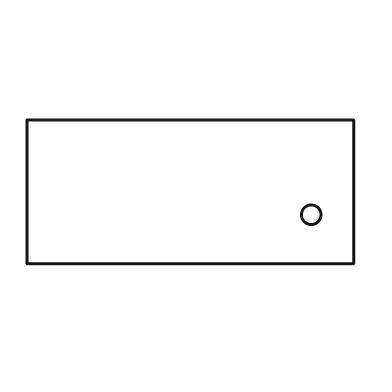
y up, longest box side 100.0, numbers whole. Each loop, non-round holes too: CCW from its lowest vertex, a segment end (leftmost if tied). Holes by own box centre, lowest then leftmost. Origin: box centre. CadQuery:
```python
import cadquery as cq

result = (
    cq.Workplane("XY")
    .moveTo(-50.0, -22.0)
    .lineTo(50.0, -22.0)
    .lineTo(50.0, 22.0)
    .lineTo(-50.0, 22.0)
    .close()
    .moveTo(37.0, -7.0)
    .circle(3.0)
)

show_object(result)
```